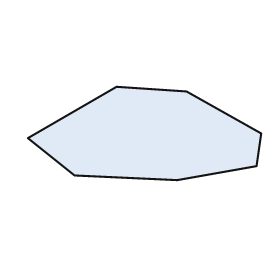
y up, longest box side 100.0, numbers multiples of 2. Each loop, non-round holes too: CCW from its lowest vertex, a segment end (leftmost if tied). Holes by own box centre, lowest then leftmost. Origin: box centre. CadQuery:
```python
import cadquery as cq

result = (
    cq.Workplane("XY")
    .moveTo(14.0, -20.0)
    .lineTo(48.0, -14.0)
    .lineTo(50.0, 0.0)
    .lineTo(18.0, 18.0)
    .lineTo(-12.0, 20.0)
    .lineTo(-50.0, -2.0)
    .lineTo(-30.0, -18.0)
    .close()
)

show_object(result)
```